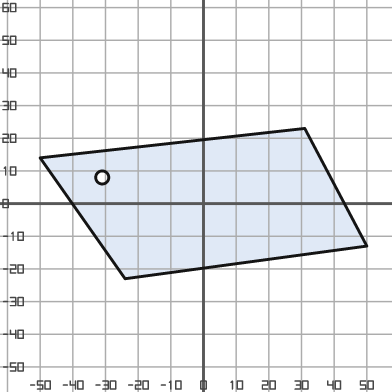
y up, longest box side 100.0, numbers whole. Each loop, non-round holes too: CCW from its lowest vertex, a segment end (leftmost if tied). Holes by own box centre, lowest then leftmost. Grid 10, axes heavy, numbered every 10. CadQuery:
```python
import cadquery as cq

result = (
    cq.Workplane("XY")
    .moveTo(-24.0, -23.0)
    .lineTo(50.0, -13.0)
    .lineTo(31.0, 23.0)
    .lineTo(-50.0, 14.0)
    .close()
    .moveTo(-31.0, 8.0)
    .circle(2.0)
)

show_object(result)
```